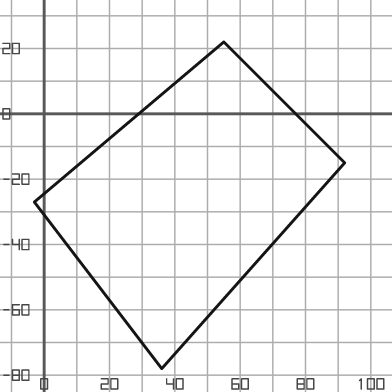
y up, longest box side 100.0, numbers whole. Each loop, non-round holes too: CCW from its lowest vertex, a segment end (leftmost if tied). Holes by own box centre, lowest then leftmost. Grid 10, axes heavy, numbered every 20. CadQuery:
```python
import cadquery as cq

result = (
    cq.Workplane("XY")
    .moveTo(36.0, -78.0)
    .lineTo(92.0, -15.0)
    .lineTo(55.0, 22.0)
    .lineTo(-3.0, -27.0)
    .close()
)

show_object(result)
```